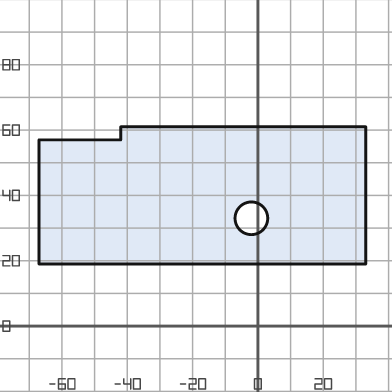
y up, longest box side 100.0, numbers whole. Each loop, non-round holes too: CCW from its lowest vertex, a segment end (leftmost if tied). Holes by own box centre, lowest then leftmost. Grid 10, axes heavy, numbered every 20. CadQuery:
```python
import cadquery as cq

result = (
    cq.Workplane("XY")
    .moveTo(-67.0, 19.0)
    .lineTo(33.0, 19.0)
    .lineTo(33.0, 61.0)
    .lineTo(-42.0, 61.0)
    .lineTo(-42.0, 57.0)
    .lineTo(-67.0, 57.0)
    .close()
    .moveTo(-2.0, 33.0)
    .circle(5.0)
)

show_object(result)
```